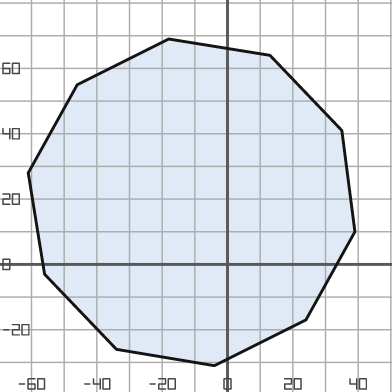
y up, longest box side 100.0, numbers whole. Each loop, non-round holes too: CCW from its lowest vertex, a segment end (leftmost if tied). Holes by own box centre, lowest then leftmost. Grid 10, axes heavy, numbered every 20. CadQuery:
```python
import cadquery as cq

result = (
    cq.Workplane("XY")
    .moveTo(-4.0, -31.0)
    .lineTo(24.0, -17.0)
    .lineTo(39.0, 10.0)
    .lineTo(35.0, 41.0)
    .lineTo(13.0, 64.0)
    .lineTo(-18.0, 69.0)
    .lineTo(-46.0, 55.0)
    .lineTo(-61.0, 28.0)
    .lineTo(-56.0, -3.0)
    .lineTo(-34.0, -26.0)
    .close()
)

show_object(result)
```